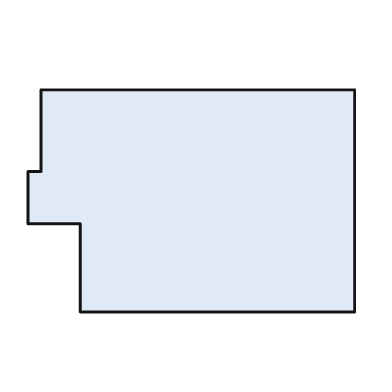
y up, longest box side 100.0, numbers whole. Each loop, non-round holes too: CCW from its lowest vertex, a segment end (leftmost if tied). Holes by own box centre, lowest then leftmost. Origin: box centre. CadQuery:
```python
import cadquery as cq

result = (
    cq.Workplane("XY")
    .moveTo(-34.0, -34.0)
    .lineTo(50.0, -34.0)
    .lineTo(50.0, 34.0)
    .lineTo(-46.0, 34.0)
    .lineTo(-46.0, 9.0)
    .lineTo(-50.0, 9.0)
    .lineTo(-50.0, -7.0)
    .lineTo(-34.0, -7.0)
    .close()
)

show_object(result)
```